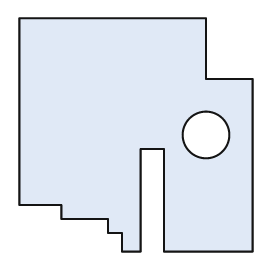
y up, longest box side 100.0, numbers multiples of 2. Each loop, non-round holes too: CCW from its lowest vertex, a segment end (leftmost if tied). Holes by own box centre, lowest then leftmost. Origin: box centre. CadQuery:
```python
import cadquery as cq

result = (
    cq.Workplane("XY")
    .moveTo(-6.0, -50.0)
    .lineTo(2.0, -50.0)
    .lineTo(2.0, -6.0)
    .lineTo(12.0, -6.0)
    .lineTo(12.0, -50.0)
    .lineTo(50.0, -50.0)
    .lineTo(50.0, 24.0)
    .lineTo(30.0, 24.0)
    .lineTo(30.0, 50.0)
    .lineTo(-50.0, 50.0)
    .lineTo(-50.0, -30.0)
    .lineTo(-32.0, -30.0)
    .lineTo(-32.0, -36.0)
    .lineTo(-12.0, -36.0)
    .lineTo(-12.0, -42.0)
    .lineTo(-6.0, -42.0)
    .close()
    .moveTo(30.0, 0.0)
    .circle(10.0)
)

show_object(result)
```